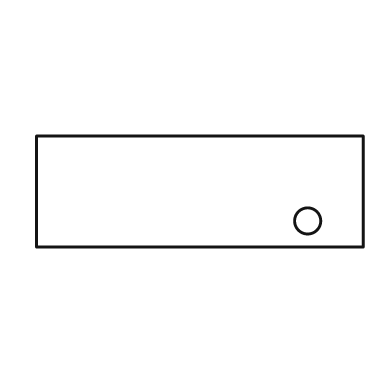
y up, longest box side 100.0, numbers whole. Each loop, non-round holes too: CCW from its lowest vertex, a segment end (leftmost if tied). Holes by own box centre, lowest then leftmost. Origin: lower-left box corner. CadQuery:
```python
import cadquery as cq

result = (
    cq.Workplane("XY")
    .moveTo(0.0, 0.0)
    .lineTo(100.0, 0.0)
    .lineTo(100.0, 34.0)
    .lineTo(0.0, 34.0)
    .close()
    .moveTo(83.0, 8.0)
    .circle(4.0)
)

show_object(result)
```